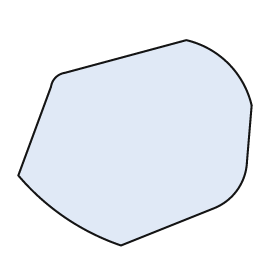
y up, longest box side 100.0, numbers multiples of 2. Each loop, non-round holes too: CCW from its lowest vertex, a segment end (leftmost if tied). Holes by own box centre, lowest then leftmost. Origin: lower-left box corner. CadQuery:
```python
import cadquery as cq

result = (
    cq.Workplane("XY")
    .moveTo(44.0, 0.0)
    .lineTo(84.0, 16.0)
    .threePointArc((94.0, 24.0), (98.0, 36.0))
    .lineTo(100.0, 60.0)
    .threePointArc((90.0, 78.0), (72.0, 88.0))
    .lineTo(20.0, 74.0)
    .threePointArc((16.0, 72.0), (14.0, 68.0))
    .lineTo(0.0, 30.0)
    .threePointArc((20.0, 12.0), (44.0, 0.0))
    .close()
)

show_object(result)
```